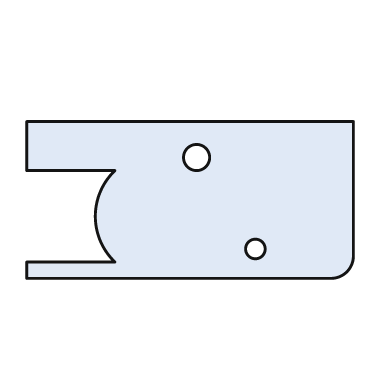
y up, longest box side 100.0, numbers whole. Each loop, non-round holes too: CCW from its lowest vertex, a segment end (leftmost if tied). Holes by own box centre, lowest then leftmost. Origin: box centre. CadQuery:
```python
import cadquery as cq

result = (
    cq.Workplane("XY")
    .moveTo(-50.0, -24.0)
    .lineTo(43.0, -24.0)
    .threePointArc((48.0, -22.0), (50.0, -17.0))
    .lineTo(50.0, 24.0)
    .lineTo(-50.0, 24.0)
    .lineTo(-50.0, 9.0)
    .lineTo(-23.0, 9.0)
    .threePointArc((-29.0, -5.0), (-23.0, -19.0))
    .lineTo(-50.0, -19.0)
    .close()
    .moveTo(20.0, -15.0)
    .circle(3.0)
    .moveTo(2.0, 13.0)
    .circle(4.0)
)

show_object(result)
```